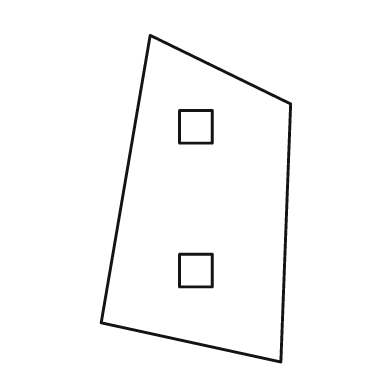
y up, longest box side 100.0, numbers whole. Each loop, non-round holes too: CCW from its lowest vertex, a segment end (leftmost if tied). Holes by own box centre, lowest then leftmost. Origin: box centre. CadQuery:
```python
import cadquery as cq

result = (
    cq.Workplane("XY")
    .moveTo(26.0, -50.0)
    .lineTo(29.0, 29.0)
    .lineTo(-14.0, 50.0)
    .lineTo(-29.0, -38.0)
    .close()
    .moveTo(-5.0, -27.0)
    .lineTo(5.0, -27.0)
    .lineTo(5.0, -17.0)
    .lineTo(-5.0, -17.0)
    .close()
    .moveTo(-5.0, 17.0)
    .lineTo(5.0, 17.0)
    .lineTo(5.0, 27.0)
    .lineTo(-5.0, 27.0)
    .close()
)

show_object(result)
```